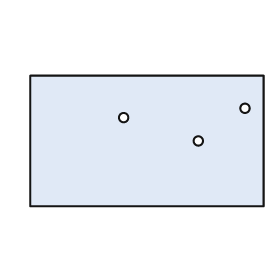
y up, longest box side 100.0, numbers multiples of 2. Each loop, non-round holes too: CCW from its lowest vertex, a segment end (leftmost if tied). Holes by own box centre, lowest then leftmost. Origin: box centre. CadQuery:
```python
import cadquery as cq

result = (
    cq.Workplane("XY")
    .moveTo(-50.0, -28.0)
    .lineTo(50.0, -28.0)
    .lineTo(50.0, 28.0)
    .lineTo(-50.0, 28.0)
    .close()
    .moveTo(22.0, 0.0)
    .circle(2.0)
    .moveTo(-10.0, 10.0)
    .circle(2.0)
    .moveTo(42.0, 14.0)
    .circle(2.0)
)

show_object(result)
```